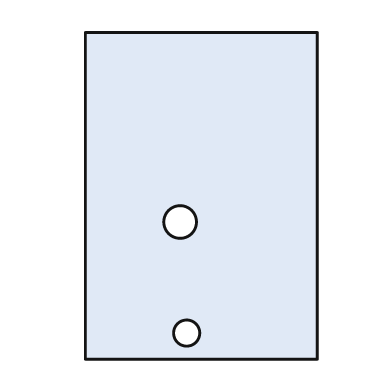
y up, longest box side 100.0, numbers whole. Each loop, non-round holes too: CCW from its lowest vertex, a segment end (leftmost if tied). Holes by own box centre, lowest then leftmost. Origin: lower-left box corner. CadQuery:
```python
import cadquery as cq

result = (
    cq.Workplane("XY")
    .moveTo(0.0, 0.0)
    .lineTo(71.0, 0.0)
    .lineTo(71.0, 100.0)
    .lineTo(0.0, 100.0)
    .close()
    .moveTo(31.0, 8.0)
    .circle(4.0)
    .moveTo(29.0, 42.0)
    .circle(5.0)
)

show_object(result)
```